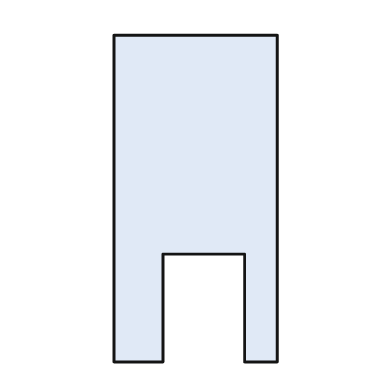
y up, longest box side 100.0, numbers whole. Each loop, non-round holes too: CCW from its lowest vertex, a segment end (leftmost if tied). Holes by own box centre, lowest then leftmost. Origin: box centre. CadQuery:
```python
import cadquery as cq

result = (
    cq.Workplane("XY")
    .moveTo(-25.0, -50.0)
    .lineTo(-10.0, -50.0)
    .lineTo(-10.0, -17.0)
    .lineTo(15.0, -17.0)
    .lineTo(15.0, -50.0)
    .lineTo(25.0, -50.0)
    .lineTo(25.0, 50.0)
    .lineTo(-25.0, 50.0)
    .close()
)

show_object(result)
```